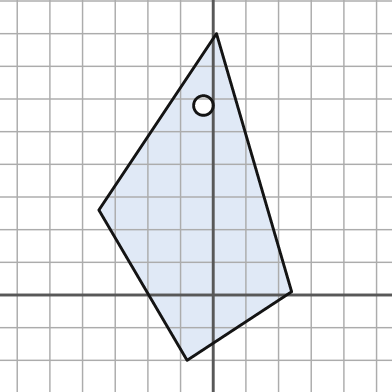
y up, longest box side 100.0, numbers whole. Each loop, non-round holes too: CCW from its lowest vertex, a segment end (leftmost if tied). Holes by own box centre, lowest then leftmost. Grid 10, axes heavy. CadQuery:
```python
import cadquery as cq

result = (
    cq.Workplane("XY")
    .moveTo(-8.0, -20.0)
    .lineTo(24.0, 1.0)
    .lineTo(1.0, 80.0)
    .lineTo(-35.0, 26.0)
    .close()
    .moveTo(-3.0, 58.0)
    .circle(3.0)
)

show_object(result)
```